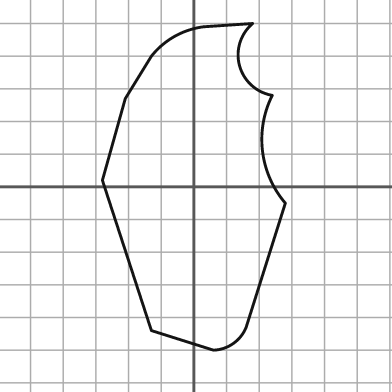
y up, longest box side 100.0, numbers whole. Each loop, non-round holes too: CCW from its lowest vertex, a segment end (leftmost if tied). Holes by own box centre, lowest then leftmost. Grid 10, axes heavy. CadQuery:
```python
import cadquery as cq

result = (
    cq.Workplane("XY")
    .moveTo(6.0, -50.0)
    .threePointArc((12.0, -48.0), (16.0, -43.0))
    .lineTo(28.0, -5.0)
    .threePointArc((21.0, 11.0), (24.0, 28.0))
    .threePointArc((14.0, 37.0), (18.0, 50.0))
    .lineTo(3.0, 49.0)
    .threePointArc((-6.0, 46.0), (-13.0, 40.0))
    .lineTo(-21.0, 27.0)
    .lineTo(-28.0, 2.0)
    .lineTo(-13.0, -44.0)
    .close()
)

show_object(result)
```